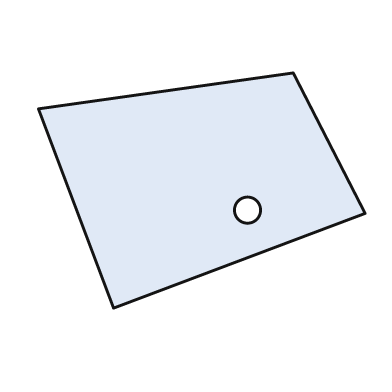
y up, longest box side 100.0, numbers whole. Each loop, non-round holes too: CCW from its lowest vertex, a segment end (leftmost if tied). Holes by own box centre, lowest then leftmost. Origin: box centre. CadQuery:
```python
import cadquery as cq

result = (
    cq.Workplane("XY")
    .moveTo(-27.0, -36.0)
    .lineTo(50.0, -7.0)
    .lineTo(28.0, 36.0)
    .lineTo(-50.0, 25.0)
    .close()
    .moveTo(14.0, -6.0)
    .circle(4.0)
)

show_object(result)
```